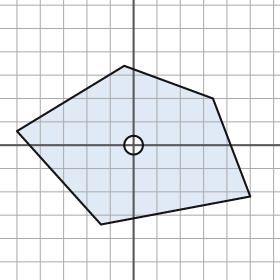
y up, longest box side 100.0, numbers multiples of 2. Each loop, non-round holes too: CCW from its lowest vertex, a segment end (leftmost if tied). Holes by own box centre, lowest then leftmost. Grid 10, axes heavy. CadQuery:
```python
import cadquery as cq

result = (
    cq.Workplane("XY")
    .moveTo(-14.0, -34.0)
    .lineTo(50.0, -22.0)
    .lineTo(34.0, 20.0)
    .lineTo(-4.0, 34.0)
    .lineTo(-50.0, 6.0)
    .close()
    .moveTo(0.0, 0.0)
    .circle(4.0)
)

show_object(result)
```